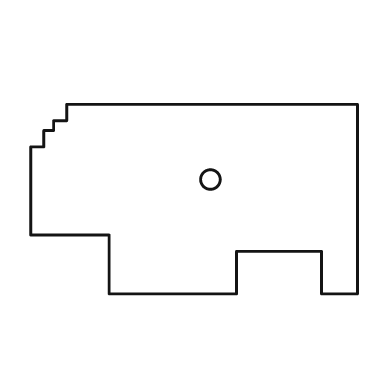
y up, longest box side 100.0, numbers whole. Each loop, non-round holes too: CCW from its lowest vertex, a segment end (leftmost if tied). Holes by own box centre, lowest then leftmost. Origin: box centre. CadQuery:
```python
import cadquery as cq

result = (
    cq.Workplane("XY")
    .moveTo(-26.0, -29.0)
    .lineTo(13.0, -29.0)
    .lineTo(13.0, -16.0)
    .lineTo(39.0, -16.0)
    .lineTo(39.0, -29.0)
    .lineTo(50.0, -29.0)
    .lineTo(50.0, 29.0)
    .lineTo(-39.0, 29.0)
    .lineTo(-39.0, 24.0)
    .lineTo(-43.0, 24.0)
    .lineTo(-43.0, 21.0)
    .lineTo(-46.0, 21.0)
    .lineTo(-46.0, 16.0)
    .lineTo(-50.0, 16.0)
    .lineTo(-50.0, -11.0)
    .lineTo(-26.0, -11.0)
    .close()
    .moveTo(5.0, 6.0)
    .circle(3.0)
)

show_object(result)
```